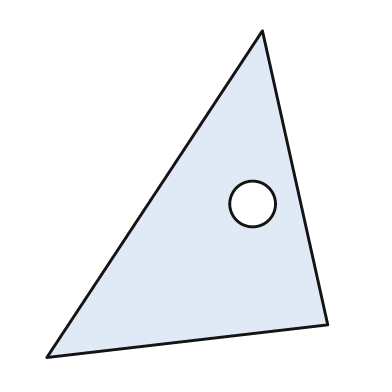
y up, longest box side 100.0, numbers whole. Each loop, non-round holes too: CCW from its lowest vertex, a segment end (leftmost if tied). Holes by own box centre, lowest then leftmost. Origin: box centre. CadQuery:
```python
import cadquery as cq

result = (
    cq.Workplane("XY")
    .moveTo(-43.0, -50.0)
    .lineTo(43.0, -40.0)
    .lineTo(23.0, 50.0)
    .close()
    .moveTo(20.0, -3.0)
    .circle(7.0)
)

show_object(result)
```